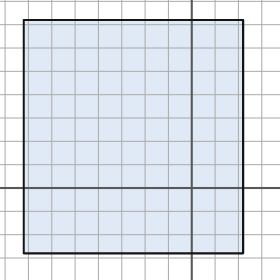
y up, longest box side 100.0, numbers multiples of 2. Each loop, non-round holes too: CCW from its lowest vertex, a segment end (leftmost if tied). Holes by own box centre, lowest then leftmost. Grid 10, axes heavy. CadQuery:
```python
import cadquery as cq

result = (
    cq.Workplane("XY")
    .moveTo(-72.0, -28.0)
    .lineTo(22.0, -28.0)
    .lineTo(22.0, 72.0)
    .lineTo(-72.0, 72.0)
    .close()
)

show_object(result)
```